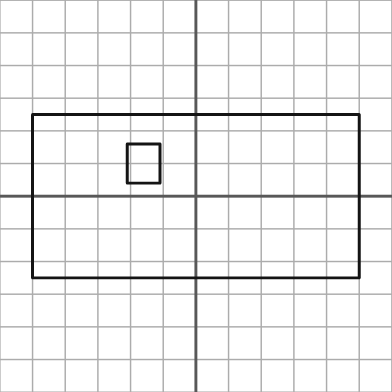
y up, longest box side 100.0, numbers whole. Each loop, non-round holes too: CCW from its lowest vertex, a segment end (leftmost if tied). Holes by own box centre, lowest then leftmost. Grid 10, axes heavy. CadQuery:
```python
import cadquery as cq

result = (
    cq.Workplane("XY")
    .moveTo(-50.0, -25.0)
    .lineTo(50.0, -25.0)
    .lineTo(50.0, 25.0)
    .lineTo(-50.0, 25.0)
    .close()
    .moveTo(-21.0, 4.0)
    .lineTo(-11.0, 4.0)
    .lineTo(-11.0, 16.0)
    .lineTo(-21.0, 16.0)
    .close()
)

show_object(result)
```